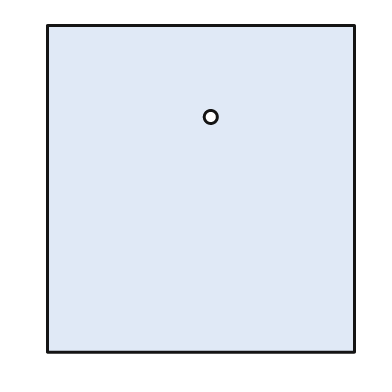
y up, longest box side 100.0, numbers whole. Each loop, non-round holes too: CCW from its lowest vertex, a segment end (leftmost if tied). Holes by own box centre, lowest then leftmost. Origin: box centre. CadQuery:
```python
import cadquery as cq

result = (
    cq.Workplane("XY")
    .moveTo(-47.0, -50.0)
    .lineTo(47.0, -50.0)
    .lineTo(47.0, 50.0)
    .lineTo(-47.0, 50.0)
    .close()
    .moveTo(3.0, 22.0)
    .circle(2.0)
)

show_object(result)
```